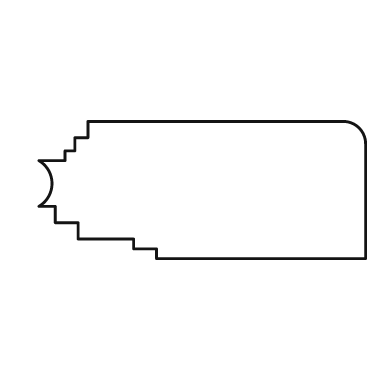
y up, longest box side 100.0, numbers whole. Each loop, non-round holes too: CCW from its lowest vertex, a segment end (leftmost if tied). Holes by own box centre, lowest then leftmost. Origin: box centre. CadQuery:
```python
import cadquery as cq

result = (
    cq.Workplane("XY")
    .moveTo(-14.0, -21.0)
    .lineTo(50.0, -21.0)
    .lineTo(50.0, 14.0)
    .threePointArc((48.0, 19.0), (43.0, 21.0))
    .lineTo(-35.0, 21.0)
    .lineTo(-35.0, 16.0)
    .lineTo(-39.0, 16.0)
    .lineTo(-39.0, 12.0)
    .lineTo(-42.0, 12.0)
    .lineTo(-42.0, 9.0)
    .lineTo(-50.0, 9.0)
    .threePointArc((-46.0, 2.0), (-50.0, -5.0))
    .lineTo(-45.0, -5.0)
    .lineTo(-45.0, -10.0)
    .lineTo(-38.0, -10.0)
    .lineTo(-38.0, -15.0)
    .lineTo(-21.0, -15.0)
    .lineTo(-21.0, -18.0)
    .lineTo(-14.0, -18.0)
    .close()
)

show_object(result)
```